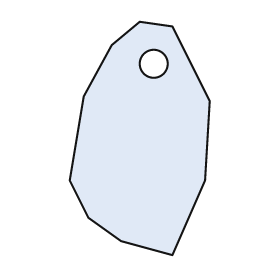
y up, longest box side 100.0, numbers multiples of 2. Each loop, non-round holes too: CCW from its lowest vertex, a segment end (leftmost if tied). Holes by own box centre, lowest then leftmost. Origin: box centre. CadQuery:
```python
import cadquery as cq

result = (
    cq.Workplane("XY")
    .moveTo(14.0, -50.0)
    .lineTo(28.0, -18.0)
    .lineTo(30.0, 16.0)
    .lineTo(14.0, 48.0)
    .lineTo(0.0, 50.0)
    .lineTo(-12.0, 40.0)
    .lineTo(-24.0, 18.0)
    .lineTo(-30.0, -18.0)
    .lineTo(-22.0, -34.0)
    .lineTo(-8.0, -44.0)
    .close()
    .moveTo(6.0, 32.0)
    .circle(6.0)
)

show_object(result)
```